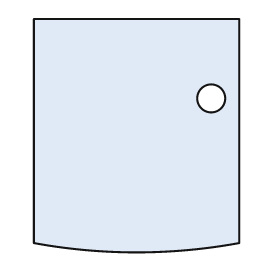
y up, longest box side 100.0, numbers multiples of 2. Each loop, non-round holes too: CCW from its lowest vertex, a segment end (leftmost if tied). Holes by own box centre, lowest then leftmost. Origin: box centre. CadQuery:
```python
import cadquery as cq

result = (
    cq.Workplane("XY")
    .moveTo(-44.0, -46.0)
    .threePointArc((0.0, -50.0), (44.0, -46.0))
    .lineTo(44.0, 50.0)
    .lineTo(-44.0, 50.0)
    .close()
    .moveTo(32.0, 16.0)
    .circle(6.0)
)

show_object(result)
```